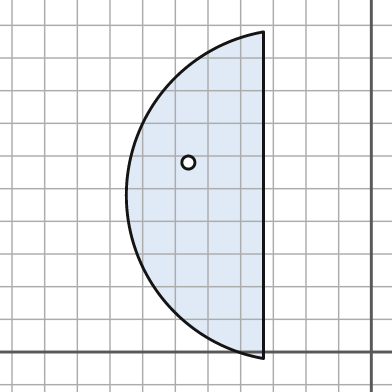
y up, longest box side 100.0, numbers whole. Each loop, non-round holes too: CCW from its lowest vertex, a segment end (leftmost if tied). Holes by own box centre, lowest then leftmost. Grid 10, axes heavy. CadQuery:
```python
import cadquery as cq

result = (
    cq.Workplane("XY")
    .moveTo(-33.0, -2.0)
    .lineTo(-33.0, 98.0)
    .threePointArc((-75.0, 48.0), (-33.0, -2.0))
    .close()
    .moveTo(-56.0, 58.0)
    .circle(2.0)
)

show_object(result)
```